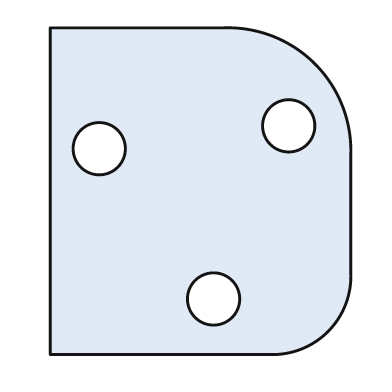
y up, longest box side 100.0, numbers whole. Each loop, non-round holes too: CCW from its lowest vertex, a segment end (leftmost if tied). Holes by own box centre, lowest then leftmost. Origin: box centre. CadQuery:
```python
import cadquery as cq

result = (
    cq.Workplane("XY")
    .moveTo(-46.0, -50.0)
    .lineTo(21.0, -50.0)
    .threePointArc((39.0, -43.0), (46.0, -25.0))
    .lineTo(46.0, 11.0)
    .threePointArc((35.0, 39.0), (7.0, 50.0))
    .lineTo(-46.0, 50.0)
    .close()
    .moveTo(4.0, -33.0)
    .circle(8.0)
    .moveTo(-31.0, 13.0)
    .circle(8.0)
    .moveTo(27.0, 20.0)
    .circle(8.0)
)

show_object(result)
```